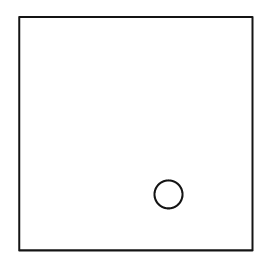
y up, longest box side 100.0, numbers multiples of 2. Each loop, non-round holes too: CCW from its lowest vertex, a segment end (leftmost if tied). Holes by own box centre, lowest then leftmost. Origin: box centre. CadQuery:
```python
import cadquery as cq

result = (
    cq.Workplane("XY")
    .moveTo(-50.0, -50.0)
    .lineTo(50.0, -50.0)
    .lineTo(50.0, 50.0)
    .lineTo(-50.0, 50.0)
    .close()
    .moveTo(14.0, -26.0)
    .circle(6.0)
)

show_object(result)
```